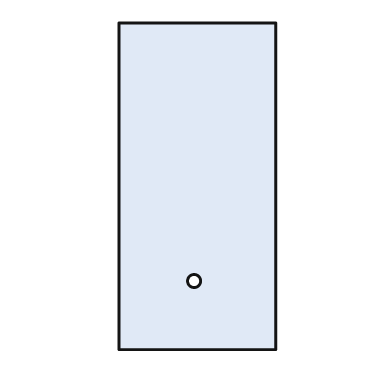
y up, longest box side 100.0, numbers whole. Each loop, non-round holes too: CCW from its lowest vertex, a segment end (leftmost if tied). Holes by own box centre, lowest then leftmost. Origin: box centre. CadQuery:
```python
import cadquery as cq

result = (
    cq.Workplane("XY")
    .moveTo(-24.0, -50.0)
    .lineTo(24.0, -50.0)
    .lineTo(24.0, 50.0)
    .lineTo(-24.0, 50.0)
    .close()
    .moveTo(-1.0, -29.0)
    .circle(2.0)
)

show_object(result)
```